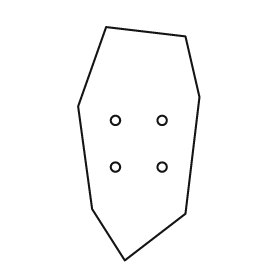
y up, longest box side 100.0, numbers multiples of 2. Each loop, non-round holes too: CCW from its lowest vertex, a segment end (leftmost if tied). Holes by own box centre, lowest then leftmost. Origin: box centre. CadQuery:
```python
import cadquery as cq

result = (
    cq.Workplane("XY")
    .moveTo(-6.0, -50.0)
    .lineTo(20.0, -30.0)
    .lineTo(26.0, 20.0)
    .lineTo(20.0, 46.0)
    .lineTo(-14.0, 50.0)
    .lineTo(-26.0, 16.0)
    .lineTo(-20.0, -28.0)
    .close()
    .moveTo(-10.0, -10.0)
    .circle(2.0)
    .moveTo(10.0, -10.0)
    .circle(2.0)
    .moveTo(-10.0, 10.0)
    .circle(2.0)
    .moveTo(10.0, 10.0)
    .circle(2.0)
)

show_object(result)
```